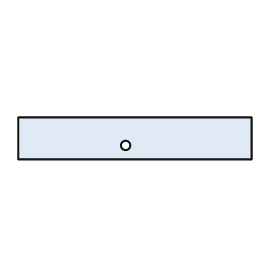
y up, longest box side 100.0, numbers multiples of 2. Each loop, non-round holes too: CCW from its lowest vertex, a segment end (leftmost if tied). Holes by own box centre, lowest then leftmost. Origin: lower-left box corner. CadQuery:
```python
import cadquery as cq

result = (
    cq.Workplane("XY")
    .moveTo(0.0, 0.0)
    .lineTo(100.0, 0.0)
    .lineTo(100.0, 18.0)
    .lineTo(0.0, 18.0)
    .close()
    .moveTo(46.0, 6.0)
    .circle(2.0)
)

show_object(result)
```